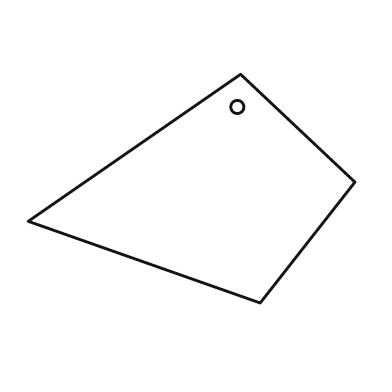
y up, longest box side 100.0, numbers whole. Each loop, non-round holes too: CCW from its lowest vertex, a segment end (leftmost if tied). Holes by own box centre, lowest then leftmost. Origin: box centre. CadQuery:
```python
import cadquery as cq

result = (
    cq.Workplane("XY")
    .moveTo(21.0, -35.0)
    .lineTo(50.0, 2.0)
    .lineTo(15.0, 35.0)
    .lineTo(-50.0, -10.0)
    .close()
    .moveTo(14.0, 25.0)
    .circle(2.0)
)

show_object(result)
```